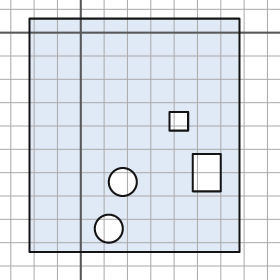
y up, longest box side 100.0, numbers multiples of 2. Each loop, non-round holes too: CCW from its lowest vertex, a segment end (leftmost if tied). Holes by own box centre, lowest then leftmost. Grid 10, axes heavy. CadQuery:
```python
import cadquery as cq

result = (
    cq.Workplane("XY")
    .moveTo(-22.0, -94.0)
    .lineTo(68.0, -94.0)
    .lineTo(68.0, 6.0)
    .lineTo(-22.0, 6.0)
    .close()
    .moveTo(12.0, -84.0)
    .circle(6.0)
    .moveTo(18.0, -64.0)
    .circle(6.0)
    .moveTo(48.0, -68.0)
    .lineTo(60.0, -68.0)
    .lineTo(60.0, -52.0)
    .lineTo(48.0, -52.0)
    .close()
    .moveTo(38.0, -42.0)
    .lineTo(46.0, -42.0)
    .lineTo(46.0, -34.0)
    .lineTo(38.0, -34.0)
    .close()
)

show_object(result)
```